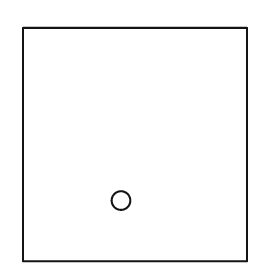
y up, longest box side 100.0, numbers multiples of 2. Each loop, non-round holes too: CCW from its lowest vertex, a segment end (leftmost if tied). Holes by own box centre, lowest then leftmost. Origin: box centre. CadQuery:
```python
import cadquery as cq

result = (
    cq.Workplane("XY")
    .moveTo(-48.0, -50.0)
    .lineTo(48.0, -50.0)
    .lineTo(48.0, 50.0)
    .lineTo(-48.0, 50.0)
    .close()
    .moveTo(-6.0, -24.0)
    .circle(4.0)
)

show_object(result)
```